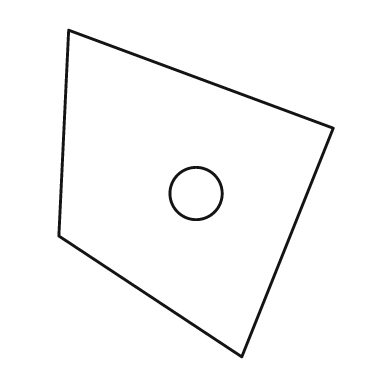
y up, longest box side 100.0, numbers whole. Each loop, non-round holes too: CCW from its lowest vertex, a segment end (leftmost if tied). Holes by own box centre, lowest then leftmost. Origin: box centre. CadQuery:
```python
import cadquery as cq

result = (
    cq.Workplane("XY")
    .moveTo(14.0, -50.0)
    .lineTo(42.0, 20.0)
    .lineTo(-39.0, 50.0)
    .lineTo(-42.0, -13.0)
    .close()
    .moveTo(0.0, 0.0)
    .circle(8.0)
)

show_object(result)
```